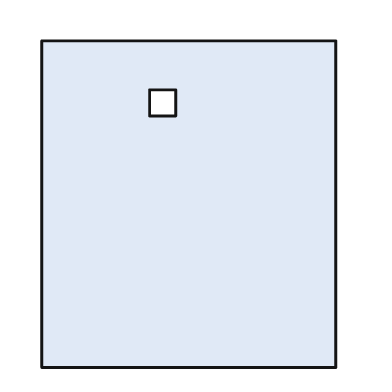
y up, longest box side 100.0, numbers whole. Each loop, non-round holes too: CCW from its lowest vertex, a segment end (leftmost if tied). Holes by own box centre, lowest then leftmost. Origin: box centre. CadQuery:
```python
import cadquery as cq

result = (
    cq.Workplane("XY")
    .moveTo(-45.0, -50.0)
    .lineTo(45.0, -50.0)
    .lineTo(45.0, 50.0)
    .lineTo(-45.0, 50.0)
    .close()
    .moveTo(-12.0, 27.0)
    .lineTo(-4.0, 27.0)
    .lineTo(-4.0, 35.0)
    .lineTo(-12.0, 35.0)
    .close()
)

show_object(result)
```